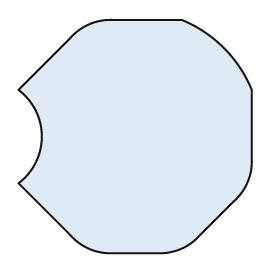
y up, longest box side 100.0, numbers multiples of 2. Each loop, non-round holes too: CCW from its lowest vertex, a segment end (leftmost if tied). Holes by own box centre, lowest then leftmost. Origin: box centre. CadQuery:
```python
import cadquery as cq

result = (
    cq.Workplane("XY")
    .moveTo(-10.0, -50.0)
    .lineTo(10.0, -50.0)
    .threePointArc((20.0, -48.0), (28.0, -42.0))
    .lineTo(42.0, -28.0)
    .threePointArc((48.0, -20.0), (50.0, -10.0))
    .lineTo(50.0, 20.0)
    .threePointArc((38.0, 38.0), (20.0, 50.0))
    .lineTo(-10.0, 50.0)
    .threePointArc((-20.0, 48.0), (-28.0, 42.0))
    .lineTo(-50.0, 20.0)
    .threePointArc((-40.0, 0.0), (-50.0, -20.0))
    .lineTo(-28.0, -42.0)
    .threePointArc((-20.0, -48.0), (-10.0, -50.0))
    .close()
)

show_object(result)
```